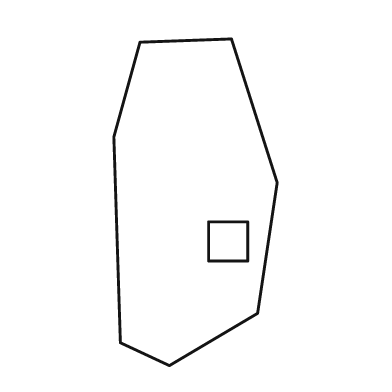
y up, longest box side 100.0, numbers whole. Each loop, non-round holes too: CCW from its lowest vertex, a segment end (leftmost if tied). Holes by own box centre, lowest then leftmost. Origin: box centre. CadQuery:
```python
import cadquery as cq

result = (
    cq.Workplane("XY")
    .moveTo(-8.0, -50.0)
    .lineTo(19.0, -34.0)
    .lineTo(25.0, 6.0)
    .lineTo(11.0, 50.0)
    .lineTo(-17.0, 49.0)
    .lineTo(-25.0, 20.0)
    .lineTo(-23.0, -43.0)
    .close()
    .moveTo(4.0, -18.0)
    .lineTo(16.0, -18.0)
    .lineTo(16.0, -6.0)
    .lineTo(4.0, -6.0)
    .close()
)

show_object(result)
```